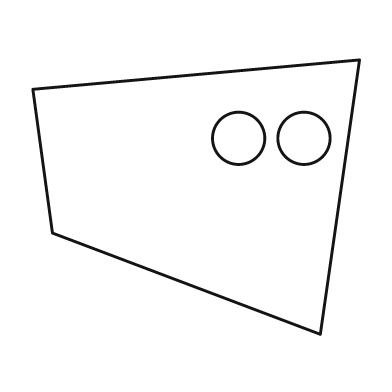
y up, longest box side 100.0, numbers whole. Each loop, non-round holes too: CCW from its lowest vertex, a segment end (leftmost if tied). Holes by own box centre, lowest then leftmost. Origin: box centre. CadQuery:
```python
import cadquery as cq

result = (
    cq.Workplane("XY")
    .moveTo(38.0, -42.0)
    .lineTo(50.0, 42.0)
    .lineTo(-50.0, 33.0)
    .lineTo(-44.0, -11.0)
    .close()
    .moveTo(13.0, 18.0)
    .circle(8.0)
    .moveTo(33.0, 18.0)
    .circle(8.0)
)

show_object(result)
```